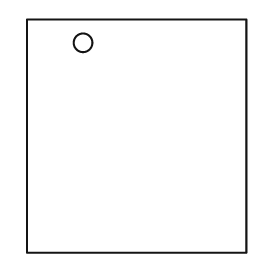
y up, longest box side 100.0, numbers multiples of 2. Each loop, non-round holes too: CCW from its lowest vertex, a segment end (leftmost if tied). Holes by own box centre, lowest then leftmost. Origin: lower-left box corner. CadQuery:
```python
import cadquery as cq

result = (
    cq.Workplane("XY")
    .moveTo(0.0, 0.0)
    .lineTo(94.0, 0.0)
    .lineTo(94.0, 100.0)
    .lineTo(0.0, 100.0)
    .close()
    .moveTo(24.0, 90.0)
    .circle(4.0)
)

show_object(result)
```